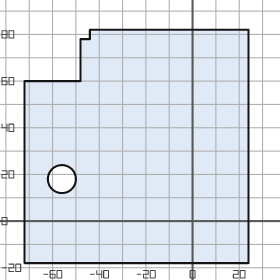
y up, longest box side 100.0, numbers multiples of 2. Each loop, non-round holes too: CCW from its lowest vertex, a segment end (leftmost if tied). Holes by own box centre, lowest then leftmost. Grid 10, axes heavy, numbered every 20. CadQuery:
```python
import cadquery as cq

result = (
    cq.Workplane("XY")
    .moveTo(-72.0, -18.0)
    .lineTo(24.0, -18.0)
    .lineTo(24.0, 82.0)
    .lineTo(-44.0, 82.0)
    .lineTo(-44.0, 78.0)
    .lineTo(-48.0, 78.0)
    .lineTo(-48.0, 60.0)
    .lineTo(-72.0, 60.0)
    .close()
    .moveTo(-56.0, 18.0)
    .circle(6.0)
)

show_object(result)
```